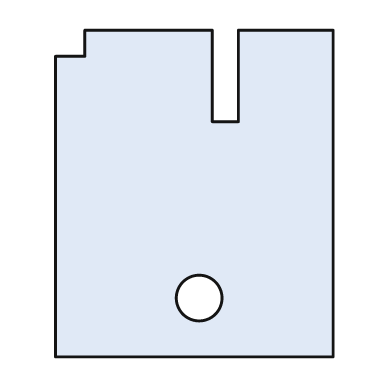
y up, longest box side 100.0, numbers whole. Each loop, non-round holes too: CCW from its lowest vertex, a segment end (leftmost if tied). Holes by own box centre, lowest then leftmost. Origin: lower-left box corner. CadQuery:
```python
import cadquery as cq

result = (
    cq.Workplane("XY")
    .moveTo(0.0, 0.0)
    .lineTo(85.0, 0.0)
    .lineTo(85.0, 100.0)
    .lineTo(56.0, 100.0)
    .lineTo(56.0, 72.0)
    .lineTo(48.0, 72.0)
    .lineTo(48.0, 100.0)
    .lineTo(9.0, 100.0)
    .lineTo(9.0, 92.0)
    .lineTo(0.0, 92.0)
    .close()
    .moveTo(44.0, 18.0)
    .circle(7.0)
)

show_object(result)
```